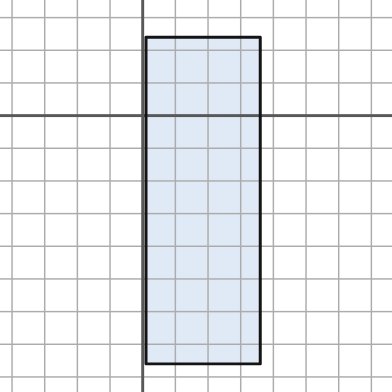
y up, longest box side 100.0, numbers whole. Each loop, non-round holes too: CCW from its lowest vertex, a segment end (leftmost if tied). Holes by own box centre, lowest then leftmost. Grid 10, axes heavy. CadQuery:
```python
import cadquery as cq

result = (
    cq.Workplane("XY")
    .moveTo(1.0, -76.0)
    .lineTo(36.0, -76.0)
    .lineTo(36.0, 24.0)
    .lineTo(1.0, 24.0)
    .close()
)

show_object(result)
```